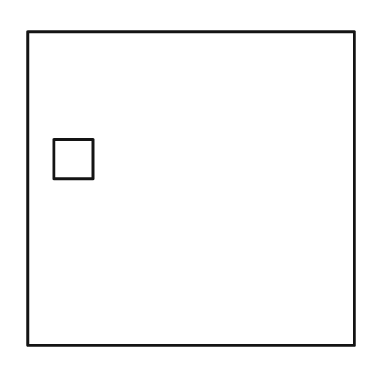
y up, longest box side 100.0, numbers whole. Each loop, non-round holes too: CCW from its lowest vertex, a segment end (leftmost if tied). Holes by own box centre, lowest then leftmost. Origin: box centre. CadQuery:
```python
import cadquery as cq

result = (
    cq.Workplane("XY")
    .moveTo(-50.0, -48.0)
    .lineTo(50.0, -48.0)
    .lineTo(50.0, 48.0)
    .lineTo(-50.0, 48.0)
    .close()
    .moveTo(-42.0, 3.0)
    .lineTo(-30.0, 3.0)
    .lineTo(-30.0, 15.0)
    .lineTo(-42.0, 15.0)
    .close()
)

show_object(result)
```